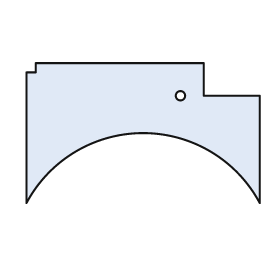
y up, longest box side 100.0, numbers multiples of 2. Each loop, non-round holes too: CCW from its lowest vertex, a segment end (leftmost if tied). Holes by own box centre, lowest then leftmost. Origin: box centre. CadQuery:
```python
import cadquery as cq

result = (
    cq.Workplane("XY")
    .moveTo(-50.0, -30.0)
    .threePointArc((0.0, 0.0), (50.0, -30.0))
    .lineTo(50.0, 16.0)
    .lineTo(26.0, 16.0)
    .lineTo(26.0, 30.0)
    .lineTo(-46.0, 30.0)
    .lineTo(-46.0, 26.0)
    .lineTo(-50.0, 26.0)
    .close()
    .moveTo(16.0, 16.0)
    .circle(2.0)
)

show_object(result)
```